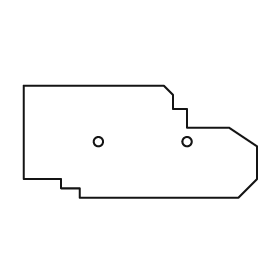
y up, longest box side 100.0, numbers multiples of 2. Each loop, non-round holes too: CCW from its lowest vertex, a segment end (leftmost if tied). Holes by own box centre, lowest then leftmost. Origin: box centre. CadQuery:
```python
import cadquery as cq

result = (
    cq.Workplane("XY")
    .moveTo(-26.0, -24.0)
    .lineTo(42.0, -24.0)
    .lineTo(50.0, -16.0)
    .lineTo(50.0, -2.0)
    .lineTo(38.0, 6.0)
    .lineTo(20.0, 6.0)
    .lineTo(20.0, 14.0)
    .lineTo(14.0, 14.0)
    .lineTo(14.0, 20.0)
    .lineTo(10.0, 24.0)
    .lineTo(-50.0, 24.0)
    .lineTo(-50.0, -16.0)
    .lineTo(-34.0, -16.0)
    .lineTo(-34.0, -20.0)
    .lineTo(-26.0, -20.0)
    .close()
    .moveTo(-18.0, 0.0)
    .circle(2.0)
    .moveTo(20.0, 0.0)
    .circle(2.0)
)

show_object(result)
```